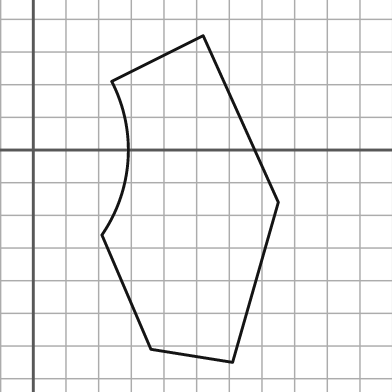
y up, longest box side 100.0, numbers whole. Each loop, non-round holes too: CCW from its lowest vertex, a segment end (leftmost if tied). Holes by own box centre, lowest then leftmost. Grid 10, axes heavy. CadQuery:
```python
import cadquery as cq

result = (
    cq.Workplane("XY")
    .moveTo(61.0, -65.0)
    .lineTo(75.0, -16.0)
    .lineTo(52.0, 35.0)
    .lineTo(24.0, 21.0)
    .threePointArc((29.0, -3.0), (21.0, -26.0))
    .lineTo(36.0, -61.0)
    .close()
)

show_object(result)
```